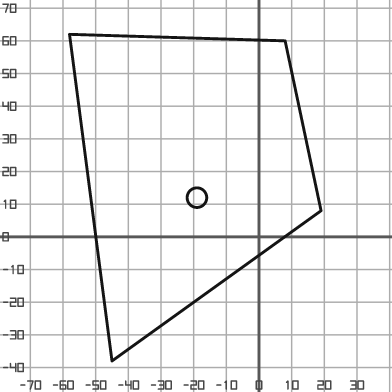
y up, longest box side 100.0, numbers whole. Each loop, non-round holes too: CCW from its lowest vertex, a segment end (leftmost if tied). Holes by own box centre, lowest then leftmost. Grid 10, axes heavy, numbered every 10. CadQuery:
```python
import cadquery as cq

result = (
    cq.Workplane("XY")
    .moveTo(-45.0, -38.0)
    .lineTo(19.0, 8.0)
    .lineTo(8.0, 60.0)
    .lineTo(-58.0, 62.0)
    .close()
    .moveTo(-19.0, 12.0)
    .circle(3.0)
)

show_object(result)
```